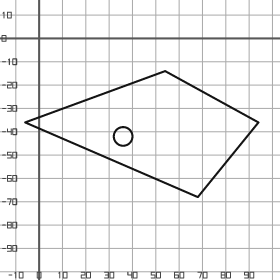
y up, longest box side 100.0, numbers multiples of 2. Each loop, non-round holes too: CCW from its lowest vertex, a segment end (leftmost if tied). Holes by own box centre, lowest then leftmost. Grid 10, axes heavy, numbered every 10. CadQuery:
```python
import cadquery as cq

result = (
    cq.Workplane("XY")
    .moveTo(68.0, -68.0)
    .lineTo(94.0, -36.0)
    .lineTo(54.0, -14.0)
    .lineTo(-6.0, -36.0)
    .close()
    .moveTo(36.0, -42.0)
    .circle(4.0)
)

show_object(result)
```